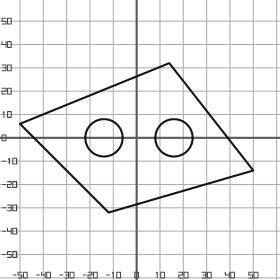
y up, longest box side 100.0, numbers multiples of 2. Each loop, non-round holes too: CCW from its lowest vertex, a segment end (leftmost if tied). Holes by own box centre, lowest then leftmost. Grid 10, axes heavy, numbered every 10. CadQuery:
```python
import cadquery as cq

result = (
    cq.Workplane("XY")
    .moveTo(-12.0, -32.0)
    .lineTo(50.0, -14.0)
    .lineTo(14.0, 32.0)
    .lineTo(-50.0, 6.0)
    .close()
    .moveTo(-14.0, 0.0)
    .circle(8.0)
    .moveTo(16.0, 0.0)
    .circle(8.0)
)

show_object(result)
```